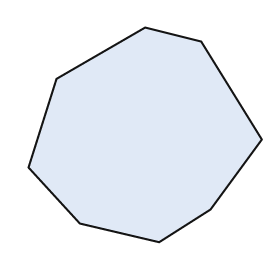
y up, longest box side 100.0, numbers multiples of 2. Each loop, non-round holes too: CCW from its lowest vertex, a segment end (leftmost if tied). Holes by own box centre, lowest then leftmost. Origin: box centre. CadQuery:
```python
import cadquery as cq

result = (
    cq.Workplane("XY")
    .moveTo(6.0, -46.0)
    .lineTo(28.0, -32.0)
    .lineTo(50.0, -2.0)
    .lineTo(24.0, 40.0)
    .lineTo(0.0, 46.0)
    .lineTo(-38.0, 24.0)
    .lineTo(-50.0, -14.0)
    .lineTo(-28.0, -38.0)
    .close()
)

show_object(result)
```